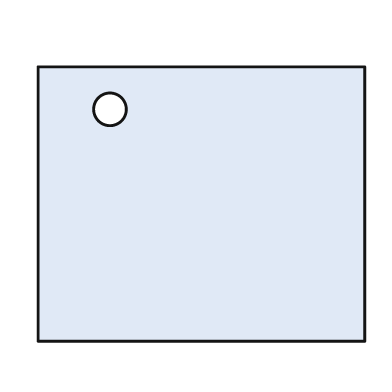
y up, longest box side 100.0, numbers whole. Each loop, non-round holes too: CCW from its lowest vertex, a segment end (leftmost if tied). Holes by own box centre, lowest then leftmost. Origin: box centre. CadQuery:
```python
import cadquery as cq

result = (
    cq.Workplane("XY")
    .moveTo(-50.0, -42.0)
    .lineTo(50.0, -42.0)
    .lineTo(50.0, 42.0)
    .lineTo(-50.0, 42.0)
    .close()
    .moveTo(-28.0, 29.0)
    .circle(5.0)
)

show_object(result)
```